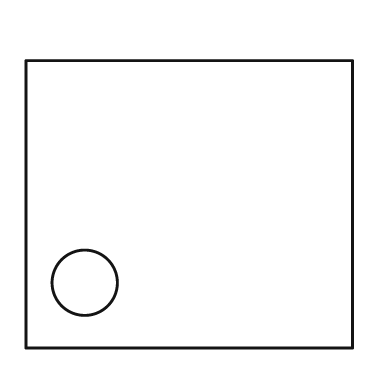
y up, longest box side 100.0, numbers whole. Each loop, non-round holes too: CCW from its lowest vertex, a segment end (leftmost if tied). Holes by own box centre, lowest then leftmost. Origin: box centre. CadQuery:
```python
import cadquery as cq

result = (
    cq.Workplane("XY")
    .moveTo(-50.0, -44.0)
    .lineTo(50.0, -44.0)
    .lineTo(50.0, 44.0)
    .lineTo(-50.0, 44.0)
    .close()
    .moveTo(-32.0, -24.0)
    .circle(10.0)
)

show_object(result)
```